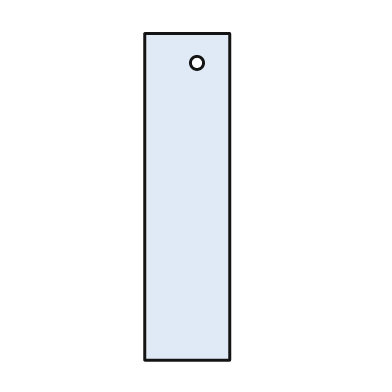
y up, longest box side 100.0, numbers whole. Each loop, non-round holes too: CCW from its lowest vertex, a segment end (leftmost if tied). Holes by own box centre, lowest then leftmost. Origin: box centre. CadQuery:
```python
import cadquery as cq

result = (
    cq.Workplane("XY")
    .moveTo(-13.0, -50.0)
    .lineTo(13.0, -50.0)
    .lineTo(13.0, 50.0)
    .lineTo(-13.0, 50.0)
    .close()
    .moveTo(3.0, 41.0)
    .circle(2.0)
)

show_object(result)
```